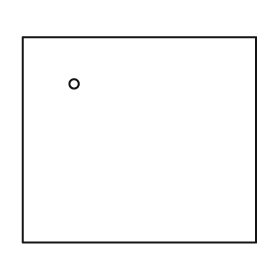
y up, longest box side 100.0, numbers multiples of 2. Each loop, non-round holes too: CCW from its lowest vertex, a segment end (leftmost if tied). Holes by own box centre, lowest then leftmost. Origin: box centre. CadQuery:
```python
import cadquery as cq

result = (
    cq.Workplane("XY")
    .moveTo(-50.0, -44.0)
    .lineTo(50.0, -44.0)
    .lineTo(50.0, 44.0)
    .lineTo(-50.0, 44.0)
    .close()
    .moveTo(-28.0, 24.0)
    .circle(2.0)
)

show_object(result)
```